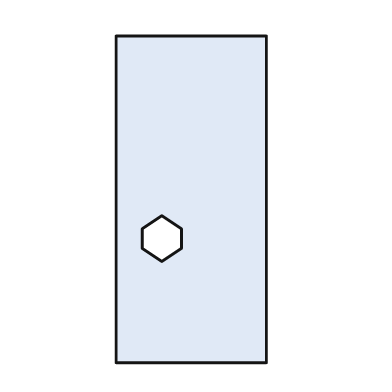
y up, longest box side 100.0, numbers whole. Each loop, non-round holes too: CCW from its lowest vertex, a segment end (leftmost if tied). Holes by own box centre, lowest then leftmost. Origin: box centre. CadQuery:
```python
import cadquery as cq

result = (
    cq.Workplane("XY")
    .moveTo(-23.0, -50.0)
    .lineTo(23.0, -50.0)
    .lineTo(23.0, 50.0)
    .lineTo(-23.0, 50.0)
    .close()
    .moveTo(-9.0, -19.0)
    .lineTo(-3.0, -15.0)
    .lineTo(-3.0, -9.0)
    .lineTo(-9.0, -5.0)
    .lineTo(-15.0, -9.0)
    .lineTo(-15.0, -15.0)
    .close()
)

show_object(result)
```